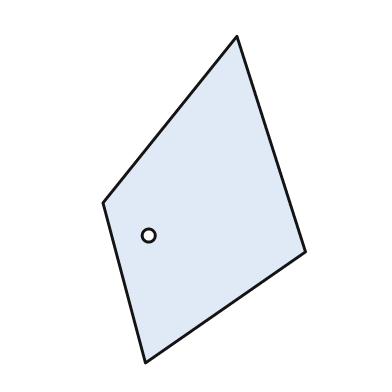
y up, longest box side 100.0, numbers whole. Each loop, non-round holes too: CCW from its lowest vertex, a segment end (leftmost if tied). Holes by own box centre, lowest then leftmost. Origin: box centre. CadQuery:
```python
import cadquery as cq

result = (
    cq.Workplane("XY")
    .moveTo(-18.0, -50.0)
    .lineTo(31.0, -16.0)
    .lineTo(10.0, 50.0)
    .lineTo(-31.0, -1.0)
    .close()
    .moveTo(-17.0, -11.0)
    .circle(2.0)
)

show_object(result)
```